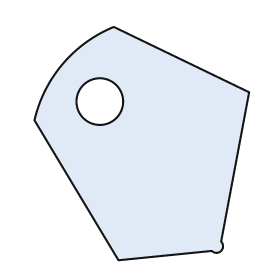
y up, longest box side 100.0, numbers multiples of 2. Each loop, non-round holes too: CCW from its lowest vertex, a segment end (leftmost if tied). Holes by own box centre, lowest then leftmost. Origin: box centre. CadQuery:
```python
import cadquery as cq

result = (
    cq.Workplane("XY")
    .moveTo(-10.0, -50.0)
    .lineTo(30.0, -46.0)
    .threePointArc((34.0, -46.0), (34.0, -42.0))
    .lineTo(46.0, 22.0)
    .lineTo(-12.0, 50.0)
    .threePointArc((-34.0, 34.0), (-46.0, 10.0))
    .close()
    .moveTo(-18.0, 18.0)
    .circle(10.0)
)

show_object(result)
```